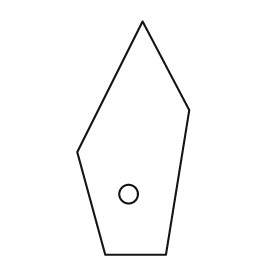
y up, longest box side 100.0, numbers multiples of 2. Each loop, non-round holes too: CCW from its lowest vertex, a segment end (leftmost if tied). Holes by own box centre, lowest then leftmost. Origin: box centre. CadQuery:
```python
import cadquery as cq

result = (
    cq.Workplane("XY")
    .moveTo(-12.0, -50.0)
    .lineTo(14.0, -50.0)
    .lineTo(24.0, 12.0)
    .lineTo(4.0, 50.0)
    .lineTo(-24.0, -6.0)
    .close()
    .moveTo(-2.0, -24.0)
    .circle(4.0)
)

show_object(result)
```